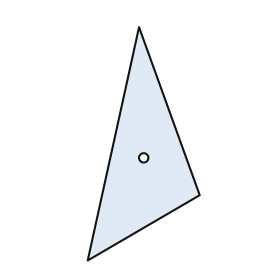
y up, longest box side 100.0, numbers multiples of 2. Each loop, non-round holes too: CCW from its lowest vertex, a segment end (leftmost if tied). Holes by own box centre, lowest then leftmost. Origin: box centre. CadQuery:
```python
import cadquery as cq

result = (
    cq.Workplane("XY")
    .moveTo(-24.0, -50.0)
    .lineTo(24.0, -22.0)
    .lineTo(-2.0, 50.0)
    .close()
    .moveTo(0.0, -6.0)
    .circle(2.0)
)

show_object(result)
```